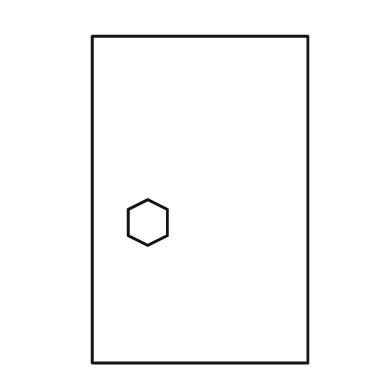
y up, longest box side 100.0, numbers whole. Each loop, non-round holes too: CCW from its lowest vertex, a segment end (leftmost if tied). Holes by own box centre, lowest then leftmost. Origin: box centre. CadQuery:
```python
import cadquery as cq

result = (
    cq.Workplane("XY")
    .moveTo(-33.0, -50.0)
    .lineTo(33.0, -50.0)
    .lineTo(33.0, 50.0)
    .lineTo(-33.0, 50.0)
    .close()
    .moveTo(-16.0, -14.0)
    .lineTo(-10.0, -11.0)
    .lineTo(-10.0, -3.0)
    .lineTo(-16.0, 0.0)
    .lineTo(-22.0, -3.0)
    .lineTo(-22.0, -11.0)
    .close()
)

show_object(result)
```